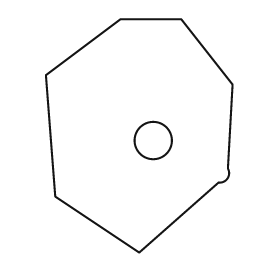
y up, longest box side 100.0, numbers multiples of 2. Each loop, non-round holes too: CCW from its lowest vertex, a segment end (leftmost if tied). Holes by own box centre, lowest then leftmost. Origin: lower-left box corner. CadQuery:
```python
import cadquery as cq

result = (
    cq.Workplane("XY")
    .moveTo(40.0, 0.0)
    .lineTo(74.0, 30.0)
    .threePointArc((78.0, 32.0), (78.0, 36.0))
    .lineTo(80.0, 72.0)
    .lineTo(58.0, 100.0)
    .lineTo(32.0, 100.0)
    .lineTo(0.0, 76.0)
    .lineTo(4.0, 24.0)
    .close()
    .moveTo(46.0, 48.0)
    .circle(8.0)
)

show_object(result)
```